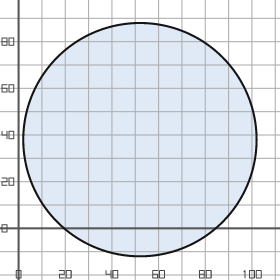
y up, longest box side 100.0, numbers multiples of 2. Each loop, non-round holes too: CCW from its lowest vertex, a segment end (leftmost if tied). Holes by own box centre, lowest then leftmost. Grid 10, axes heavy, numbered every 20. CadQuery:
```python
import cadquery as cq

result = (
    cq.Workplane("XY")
    .moveTo(52.0, 38.0)
    .circle(50.0)
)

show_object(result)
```